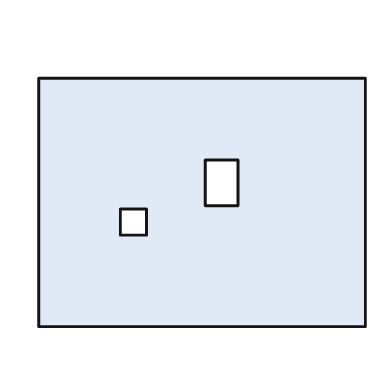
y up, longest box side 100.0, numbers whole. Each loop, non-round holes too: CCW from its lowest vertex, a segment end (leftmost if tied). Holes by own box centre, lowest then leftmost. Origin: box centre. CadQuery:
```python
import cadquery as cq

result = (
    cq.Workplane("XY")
    .moveTo(-50.0, -38.0)
    .lineTo(50.0, -38.0)
    .lineTo(50.0, 38.0)
    .lineTo(-50.0, 38.0)
    .close()
    .moveTo(-25.0, -10.0)
    .lineTo(-17.0, -10.0)
    .lineTo(-17.0, -2.0)
    .lineTo(-25.0, -2.0)
    .close()
    .moveTo(1.0, -1.0)
    .lineTo(11.0, -1.0)
    .lineTo(11.0, 13.0)
    .lineTo(1.0, 13.0)
    .close()
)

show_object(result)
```